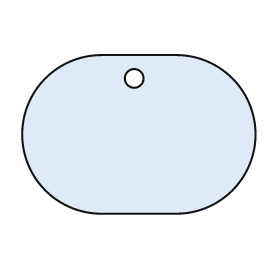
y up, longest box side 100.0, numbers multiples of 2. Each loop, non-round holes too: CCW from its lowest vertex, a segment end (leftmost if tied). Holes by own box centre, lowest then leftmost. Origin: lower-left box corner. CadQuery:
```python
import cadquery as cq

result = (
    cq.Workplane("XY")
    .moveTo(34.0, 0.0)
    .lineTo(66.0, 0.0)
    .threePointArc((100.0, 34.0), (66.0, 68.0))
    .lineTo(34.0, 68.0)
    .threePointArc((0.0, 34.0), (34.0, 0.0))
    .close()
    .moveTo(48.0, 58.0)
    .circle(4.0)
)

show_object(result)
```